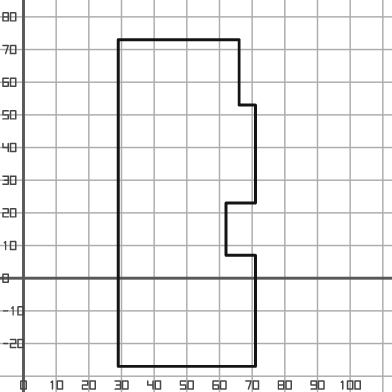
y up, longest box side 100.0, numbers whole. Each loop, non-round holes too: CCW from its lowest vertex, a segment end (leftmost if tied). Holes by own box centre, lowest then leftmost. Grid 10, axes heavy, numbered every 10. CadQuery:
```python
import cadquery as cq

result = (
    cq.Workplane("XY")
    .moveTo(29.0, -27.0)
    .lineTo(71.0, -27.0)
    .lineTo(71.0, 7.0)
    .lineTo(62.0, 7.0)
    .lineTo(62.0, 23.0)
    .lineTo(71.0, 23.0)
    .lineTo(71.0, 53.0)
    .lineTo(66.0, 53.0)
    .lineTo(66.0, 73.0)
    .lineTo(29.0, 73.0)
    .close()
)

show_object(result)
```